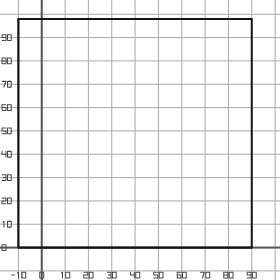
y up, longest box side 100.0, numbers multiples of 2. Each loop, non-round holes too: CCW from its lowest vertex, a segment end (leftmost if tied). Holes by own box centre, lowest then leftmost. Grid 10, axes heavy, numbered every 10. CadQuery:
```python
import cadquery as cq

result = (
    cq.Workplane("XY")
    .moveTo(-10.0, 0.0)
    .lineTo(90.0, 0.0)
    .lineTo(90.0, 98.0)
    .lineTo(-10.0, 98.0)
    .close()
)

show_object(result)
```